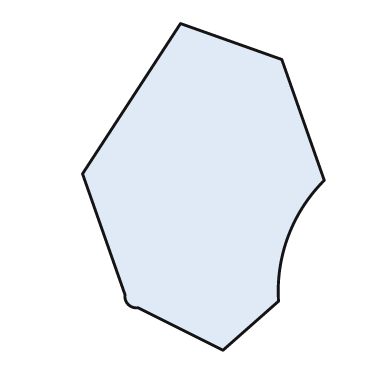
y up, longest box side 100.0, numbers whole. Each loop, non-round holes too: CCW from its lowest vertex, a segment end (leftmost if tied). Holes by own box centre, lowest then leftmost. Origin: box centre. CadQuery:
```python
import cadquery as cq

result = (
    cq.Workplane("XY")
    .moveTo(6.0, -50.0)
    .lineTo(23.0, -35.0)
    .threePointArc((26.0, -15.0), (37.0, 2.0))
    .lineTo(24.0, 39.0)
    .lineTo(-7.0, 50.0)
    .lineTo(-37.0, 4.0)
    .lineTo(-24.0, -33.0)
    .threePointArc((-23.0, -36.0), (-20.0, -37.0))
    .close()
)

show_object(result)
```